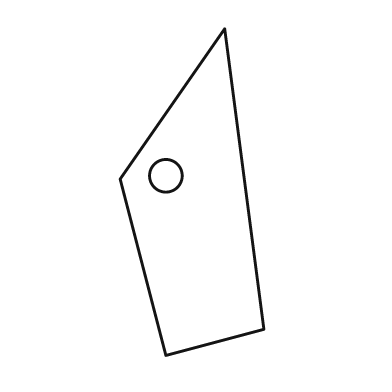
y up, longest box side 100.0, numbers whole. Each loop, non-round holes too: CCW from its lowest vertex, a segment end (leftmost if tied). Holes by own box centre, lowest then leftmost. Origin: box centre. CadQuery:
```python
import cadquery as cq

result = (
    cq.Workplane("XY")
    .moveTo(-8.0, -50.0)
    .lineTo(22.0, -42.0)
    .lineTo(10.0, 50.0)
    .lineTo(-22.0, 4.0)
    .close()
    .moveTo(-8.0, 5.0)
    .circle(5.0)
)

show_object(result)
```